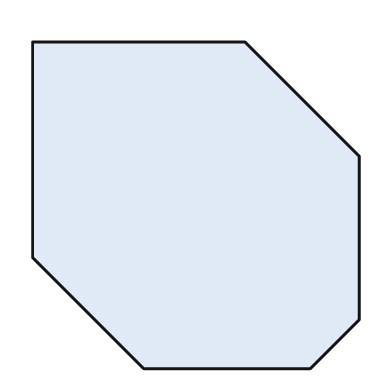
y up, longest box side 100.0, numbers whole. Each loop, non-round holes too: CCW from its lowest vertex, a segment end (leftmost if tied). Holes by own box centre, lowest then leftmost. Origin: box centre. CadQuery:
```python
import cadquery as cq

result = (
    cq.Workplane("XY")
    .moveTo(-16.0, -50.0)
    .lineTo(35.0, -50.0)
    .lineTo(50.0, -35.0)
    .lineTo(50.0, 15.0)
    .lineTo(15.0, 50.0)
    .lineTo(-50.0, 50.0)
    .lineTo(-50.0, -16.0)
    .close()
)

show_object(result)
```